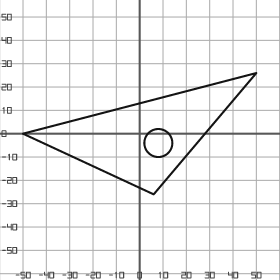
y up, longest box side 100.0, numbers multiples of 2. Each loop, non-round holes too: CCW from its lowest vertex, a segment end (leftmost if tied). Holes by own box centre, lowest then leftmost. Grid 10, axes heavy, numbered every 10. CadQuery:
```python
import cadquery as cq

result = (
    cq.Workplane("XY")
    .moveTo(6.0, -26.0)
    .lineTo(50.0, 26.0)
    .lineTo(-50.0, 0.0)
    .close()
    .moveTo(8.0, -4.0)
    .circle(6.0)
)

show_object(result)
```